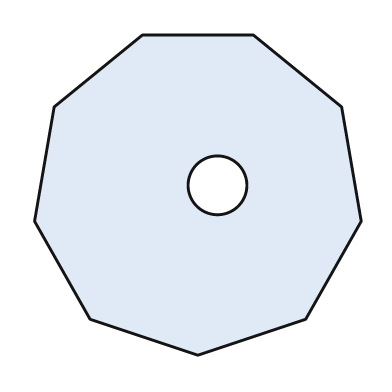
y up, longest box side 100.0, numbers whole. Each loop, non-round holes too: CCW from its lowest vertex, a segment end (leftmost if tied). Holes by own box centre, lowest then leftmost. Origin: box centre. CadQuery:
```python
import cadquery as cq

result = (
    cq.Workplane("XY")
    .moveTo(0.0, -49.0)
    .lineTo(33.0, -38.0)
    .lineTo(50.0, -8.0)
    .lineTo(44.0, 27.0)
    .lineTo(17.0, 49.0)
    .lineTo(-17.0, 49.0)
    .lineTo(-44.0, 27.0)
    .lineTo(-50.0, -8.0)
    .lineTo(-33.0, -38.0)
    .close()
    .moveTo(6.0, 3.0)
    .circle(9.0)
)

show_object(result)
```